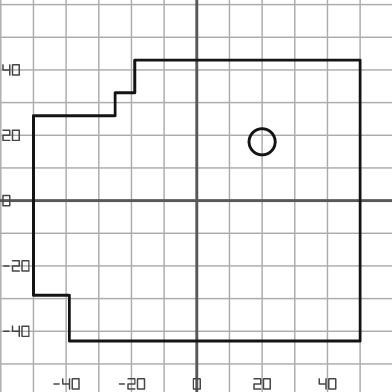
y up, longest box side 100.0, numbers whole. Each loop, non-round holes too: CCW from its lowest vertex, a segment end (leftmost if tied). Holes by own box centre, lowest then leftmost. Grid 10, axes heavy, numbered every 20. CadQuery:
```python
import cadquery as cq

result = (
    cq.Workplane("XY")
    .moveTo(-39.0, -43.0)
    .lineTo(50.0, -43.0)
    .lineTo(50.0, 43.0)
    .lineTo(-19.0, 43.0)
    .lineTo(-19.0, 33.0)
    .lineTo(-25.0, 33.0)
    .lineTo(-25.0, 26.0)
    .lineTo(-50.0, 26.0)
    .lineTo(-50.0, -29.0)
    .lineTo(-39.0, -29.0)
    .close()
    .moveTo(20.0, 18.0)
    .circle(4.0)
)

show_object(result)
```